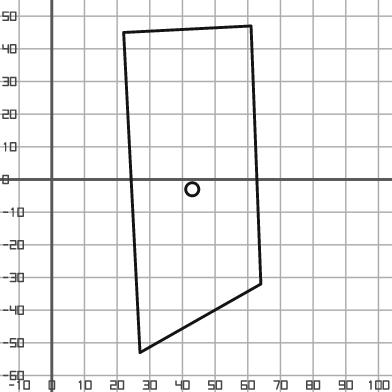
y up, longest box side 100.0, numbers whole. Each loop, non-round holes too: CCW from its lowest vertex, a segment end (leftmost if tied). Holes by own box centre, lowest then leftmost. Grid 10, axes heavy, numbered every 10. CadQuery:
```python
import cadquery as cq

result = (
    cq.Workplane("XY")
    .moveTo(27.0, -53.0)
    .lineTo(64.0, -32.0)
    .lineTo(61.0, 47.0)
    .lineTo(22.0, 45.0)
    .close()
    .moveTo(43.0, -3.0)
    .circle(2.0)
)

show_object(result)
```